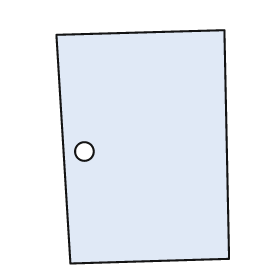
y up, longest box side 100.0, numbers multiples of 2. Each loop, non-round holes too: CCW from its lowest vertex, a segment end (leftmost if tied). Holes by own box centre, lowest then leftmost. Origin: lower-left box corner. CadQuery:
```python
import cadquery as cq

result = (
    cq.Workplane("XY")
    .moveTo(6.0, 0.0)
    .lineTo(74.0, 2.0)
    .lineTo(72.0, 100.0)
    .lineTo(0.0, 98.0)
    .close()
    .moveTo(12.0, 48.0)
    .circle(4.0)
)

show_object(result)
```